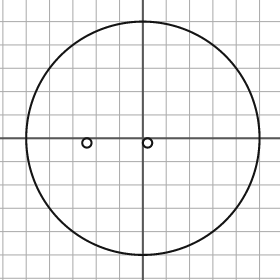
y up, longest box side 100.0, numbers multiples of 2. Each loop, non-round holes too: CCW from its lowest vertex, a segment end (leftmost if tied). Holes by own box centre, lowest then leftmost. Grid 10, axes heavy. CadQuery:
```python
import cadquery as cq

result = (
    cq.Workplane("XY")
    .moveTo(0.0, 0.0)
    .circle(50.0)
    .moveTo(-24.0, -2.0)
    .circle(2.0)
    .moveTo(2.0, -2.0)
    .circle(2.0)
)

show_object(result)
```